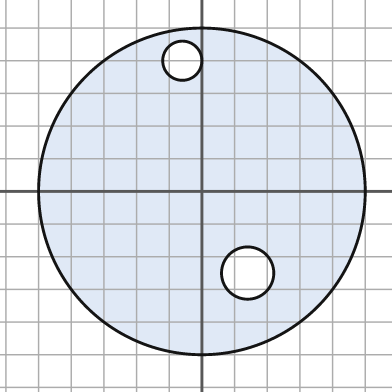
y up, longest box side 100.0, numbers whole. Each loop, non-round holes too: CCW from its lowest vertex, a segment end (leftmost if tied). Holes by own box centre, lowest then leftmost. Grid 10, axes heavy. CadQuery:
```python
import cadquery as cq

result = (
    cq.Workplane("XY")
    .moveTo(0.0, 0.0)
    .circle(50.0)
    .moveTo(14.0, -25.0)
    .circle(8.0)
    .moveTo(-6.0, 40.0)
    .circle(6.0)
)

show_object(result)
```